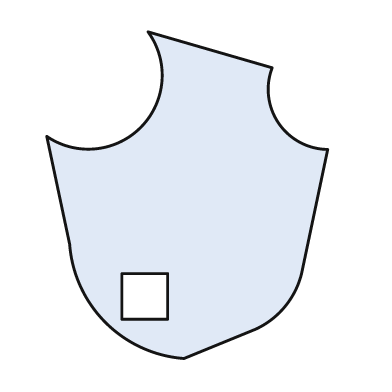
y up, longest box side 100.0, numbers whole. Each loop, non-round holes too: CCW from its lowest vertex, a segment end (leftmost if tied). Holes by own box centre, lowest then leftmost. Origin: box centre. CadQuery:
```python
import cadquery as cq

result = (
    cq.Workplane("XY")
    .moveTo(-1.0, -50.0)
    .lineTo(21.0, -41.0)
    .threePointArc((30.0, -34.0), (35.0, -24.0))
    .lineTo(43.0, 14.0)
    .threePointArc((28.0, 22.0), (26.0, 39.0))
    .lineTo(-12.0, 50.0)
    .threePointArc((-14.0, 21.0), (-43.0, 18.0))
    .lineTo(-36.0, -15.0)
    .threePointArc((-25.0, -39.0), (-1.0, -50.0))
    .close()
    .moveTo(-20.0, -38.0)
    .lineTo(-6.0, -38.0)
    .lineTo(-6.0, -24.0)
    .lineTo(-20.0, -24.0)
    .close()
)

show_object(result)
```